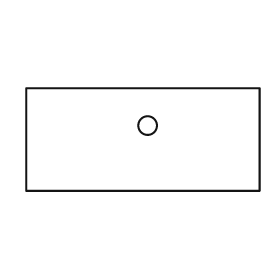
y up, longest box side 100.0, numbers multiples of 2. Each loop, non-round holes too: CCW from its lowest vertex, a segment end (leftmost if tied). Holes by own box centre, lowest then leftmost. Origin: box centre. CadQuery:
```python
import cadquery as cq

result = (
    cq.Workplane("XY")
    .moveTo(-50.0, -22.0)
    .lineTo(50.0, -22.0)
    .lineTo(50.0, 22.0)
    .lineTo(-50.0, 22.0)
    .close()
    .moveTo(2.0, 6.0)
    .circle(4.0)
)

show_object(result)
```